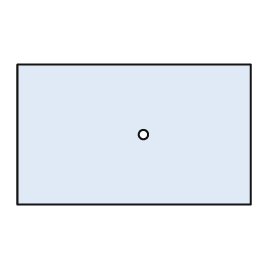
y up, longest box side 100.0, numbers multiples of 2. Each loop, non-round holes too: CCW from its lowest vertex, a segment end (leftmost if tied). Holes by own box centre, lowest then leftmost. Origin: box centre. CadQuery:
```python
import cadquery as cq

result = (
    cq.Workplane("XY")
    .moveTo(-50.0, -30.0)
    .lineTo(50.0, -30.0)
    .lineTo(50.0, 30.0)
    .lineTo(-50.0, 30.0)
    .close()
    .moveTo(4.0, 0.0)
    .circle(2.0)
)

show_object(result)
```